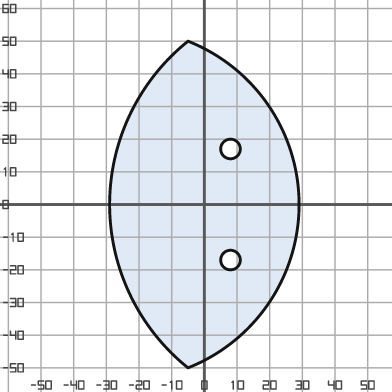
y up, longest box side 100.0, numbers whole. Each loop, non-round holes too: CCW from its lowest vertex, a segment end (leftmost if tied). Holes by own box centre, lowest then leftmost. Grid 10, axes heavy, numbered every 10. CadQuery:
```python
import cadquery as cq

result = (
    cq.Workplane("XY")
    .moveTo(-5.0, -50.0)
    .threePointArc((29.0, 0.0), (-5.0, 50.0))
    .threePointArc((-29.0, 0.0), (-5.0, -50.0))
    .close()
    .moveTo(8.0, -17.0)
    .circle(3.0)
    .moveTo(8.0, 17.0)
    .circle(3.0)
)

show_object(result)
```